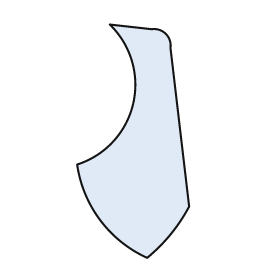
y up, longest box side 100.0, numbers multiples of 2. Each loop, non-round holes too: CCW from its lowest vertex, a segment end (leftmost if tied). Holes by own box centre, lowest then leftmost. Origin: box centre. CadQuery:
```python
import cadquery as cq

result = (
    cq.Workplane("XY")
    .moveTo(6.0, -50.0)
    .threePointArc((16.0, -40.0), (24.0, -28.0))
    .lineTo(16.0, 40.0)
    .threePointArc((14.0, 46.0), (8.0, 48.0))
    .lineTo(-10.0, 50.0)
    .threePointArc((0.0, 16.0), (-24.0, -10.0))
    .threePointArc((-14.0, -34.0), (6.0, -50.0))
    .close()
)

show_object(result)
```